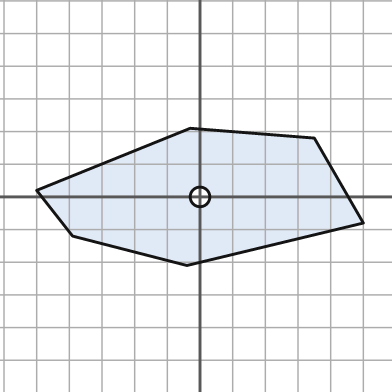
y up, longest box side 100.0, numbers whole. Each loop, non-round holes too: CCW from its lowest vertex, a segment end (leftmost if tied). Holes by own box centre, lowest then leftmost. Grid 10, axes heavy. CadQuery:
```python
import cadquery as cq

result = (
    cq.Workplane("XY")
    .moveTo(-4.0, -21.0)
    .lineTo(50.0, -8.0)
    .lineTo(35.0, 18.0)
    .lineTo(-3.0, 21.0)
    .lineTo(-50.0, 2.0)
    .lineTo(-39.0, -12.0)
    .close()
    .moveTo(0.0, 0.0)
    .circle(3.0)
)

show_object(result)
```